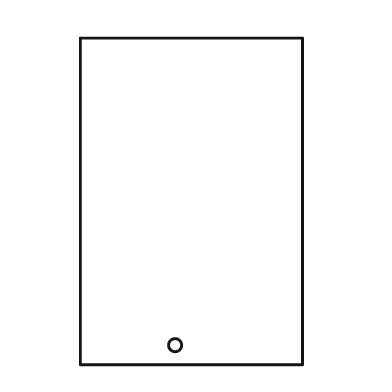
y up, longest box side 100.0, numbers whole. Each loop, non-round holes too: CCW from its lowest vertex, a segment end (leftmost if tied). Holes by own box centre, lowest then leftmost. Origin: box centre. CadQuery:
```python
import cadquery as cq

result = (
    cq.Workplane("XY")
    .moveTo(-34.0, -50.0)
    .lineTo(34.0, -50.0)
    .lineTo(34.0, 50.0)
    .lineTo(-34.0, 50.0)
    .close()
    .moveTo(-5.0, -44.0)
    .circle(2.0)
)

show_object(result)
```